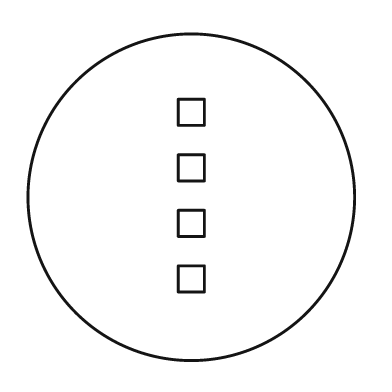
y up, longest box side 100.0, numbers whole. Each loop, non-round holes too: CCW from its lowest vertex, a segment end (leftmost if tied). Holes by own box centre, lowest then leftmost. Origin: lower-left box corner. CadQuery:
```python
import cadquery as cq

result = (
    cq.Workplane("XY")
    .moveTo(50.0, 50.0)
    .circle(50.0)
    .moveTo(46.0, 21.0)
    .lineTo(54.0, 21.0)
    .lineTo(54.0, 29.0)
    .lineTo(46.0, 29.0)
    .close()
    .moveTo(46.0, 38.0)
    .lineTo(54.0, 38.0)
    .lineTo(54.0, 46.0)
    .lineTo(46.0, 46.0)
    .close()
    .moveTo(46.0, 55.0)
    .lineTo(54.0, 55.0)
    .lineTo(54.0, 63.0)
    .lineTo(46.0, 63.0)
    .close()
    .moveTo(46.0, 72.0)
    .lineTo(54.0, 72.0)
    .lineTo(54.0, 80.0)
    .lineTo(46.0, 80.0)
    .close()
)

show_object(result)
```